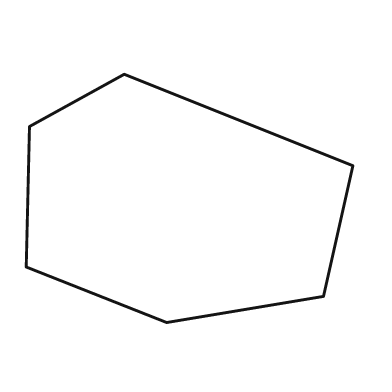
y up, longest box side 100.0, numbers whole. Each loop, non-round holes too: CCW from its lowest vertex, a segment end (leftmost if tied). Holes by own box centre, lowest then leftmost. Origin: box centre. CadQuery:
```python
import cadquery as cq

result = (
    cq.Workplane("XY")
    .moveTo(-7.0, -38.0)
    .lineTo(41.0, -30.0)
    .lineTo(50.0, 10.0)
    .lineTo(-20.0, 38.0)
    .lineTo(-49.0, 22.0)
    .lineTo(-50.0, -21.0)
    .close()
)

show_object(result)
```